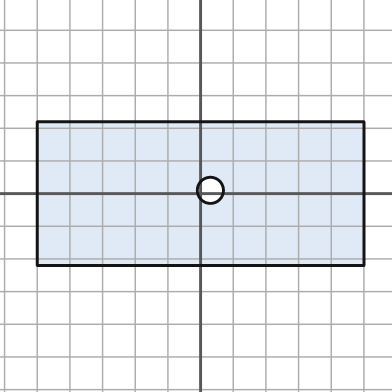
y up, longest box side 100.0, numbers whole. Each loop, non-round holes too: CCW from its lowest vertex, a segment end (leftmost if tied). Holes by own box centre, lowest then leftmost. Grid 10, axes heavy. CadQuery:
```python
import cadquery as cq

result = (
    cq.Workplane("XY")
    .moveTo(-50.0, -22.0)
    .lineTo(50.0, -22.0)
    .lineTo(50.0, 22.0)
    .lineTo(-50.0, 22.0)
    .close()
    .moveTo(3.0, 1.0)
    .circle(4.0)
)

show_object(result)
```